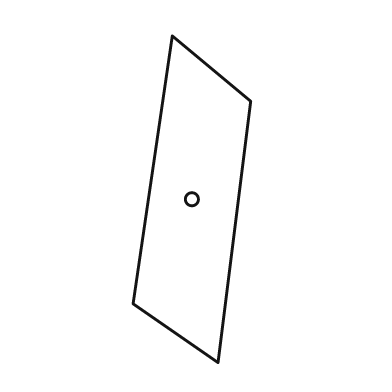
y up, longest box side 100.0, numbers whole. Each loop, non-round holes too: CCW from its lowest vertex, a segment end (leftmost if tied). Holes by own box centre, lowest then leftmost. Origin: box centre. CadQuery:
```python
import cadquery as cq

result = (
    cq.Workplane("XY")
    .moveTo(8.0, -50.0)
    .lineTo(18.0, 30.0)
    .lineTo(-6.0, 50.0)
    .lineTo(-18.0, -32.0)
    .close()
    .moveTo(0.0, 0.0)
    .circle(2.0)
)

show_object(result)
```